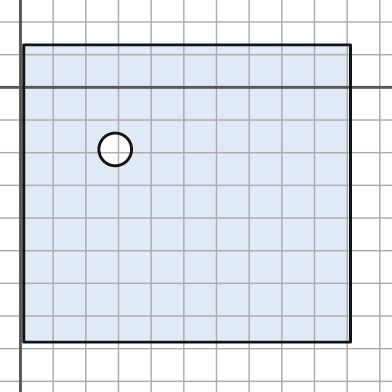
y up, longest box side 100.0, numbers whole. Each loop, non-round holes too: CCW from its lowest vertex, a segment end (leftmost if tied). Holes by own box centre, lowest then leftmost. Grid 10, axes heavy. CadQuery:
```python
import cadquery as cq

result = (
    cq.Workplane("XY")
    .moveTo(1.0, -78.0)
    .lineTo(101.0, -78.0)
    .lineTo(101.0, 13.0)
    .lineTo(1.0, 13.0)
    .close()
    .moveTo(29.0, -19.0)
    .circle(5.0)
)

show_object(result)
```